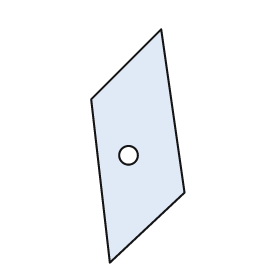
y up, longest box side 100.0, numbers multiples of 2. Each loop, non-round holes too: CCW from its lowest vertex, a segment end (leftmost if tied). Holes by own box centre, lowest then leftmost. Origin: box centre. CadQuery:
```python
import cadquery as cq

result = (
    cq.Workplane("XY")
    .moveTo(-12.0, -50.0)
    .lineTo(20.0, -20.0)
    .lineTo(10.0, 50.0)
    .lineTo(-20.0, 20.0)
    .close()
    .moveTo(-4.0, -4.0)
    .circle(4.0)
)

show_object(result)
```